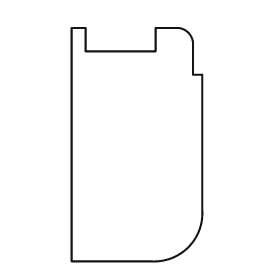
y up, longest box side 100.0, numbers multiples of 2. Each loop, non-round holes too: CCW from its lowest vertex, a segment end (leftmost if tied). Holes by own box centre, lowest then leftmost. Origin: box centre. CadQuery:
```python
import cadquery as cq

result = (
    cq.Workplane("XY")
    .moveTo(-28.0, -50.0)
    .lineTo(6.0, -50.0)
    .threePointArc((22.0, -44.0), (28.0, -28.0))
    .lineTo(28.0, 30.0)
    .lineTo(24.0, 30.0)
    .lineTo(24.0, 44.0)
    .threePointArc((22.0, 48.0), (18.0, 50.0))
    .lineTo(8.0, 50.0)
    .lineTo(8.0, 40.0)
    .lineTo(-22.0, 40.0)
    .lineTo(-22.0, 50.0)
    .lineTo(-28.0, 50.0)
    .close()
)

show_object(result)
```